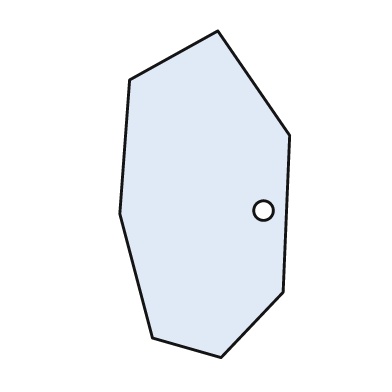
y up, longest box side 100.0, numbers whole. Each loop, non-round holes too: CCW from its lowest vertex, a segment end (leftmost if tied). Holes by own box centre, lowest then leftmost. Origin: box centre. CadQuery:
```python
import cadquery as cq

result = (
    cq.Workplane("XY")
    .moveTo(5.0, -50.0)
    .lineTo(24.0, -30.0)
    .lineTo(26.0, 18.0)
    .lineTo(4.0, 50.0)
    .lineTo(-23.0, 35.0)
    .lineTo(-26.0, -6.0)
    .lineTo(-16.0, -44.0)
    .close()
    .moveTo(18.0, -5.0)
    .circle(3.0)
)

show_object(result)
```